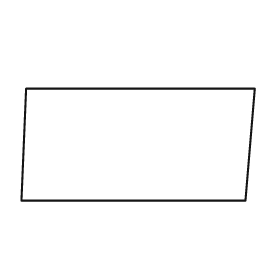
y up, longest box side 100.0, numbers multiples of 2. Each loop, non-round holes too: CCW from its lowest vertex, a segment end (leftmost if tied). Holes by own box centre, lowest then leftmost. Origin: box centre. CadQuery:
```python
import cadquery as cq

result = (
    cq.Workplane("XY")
    .moveTo(-50.0, -24.0)
    .lineTo(46.0, -24.0)
    .lineTo(50.0, 24.0)
    .lineTo(-48.0, 24.0)
    .close()
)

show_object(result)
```